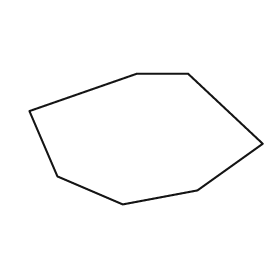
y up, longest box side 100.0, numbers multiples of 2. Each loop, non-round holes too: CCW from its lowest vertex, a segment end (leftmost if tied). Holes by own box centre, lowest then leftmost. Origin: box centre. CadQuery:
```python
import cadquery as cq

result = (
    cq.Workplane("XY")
    .moveTo(-10.0, -28.0)
    .lineTo(22.0, -22.0)
    .lineTo(50.0, -2.0)
    .lineTo(18.0, 28.0)
    .lineTo(-4.0, 28.0)
    .lineTo(-50.0, 12.0)
    .lineTo(-38.0, -16.0)
    .close()
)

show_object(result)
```